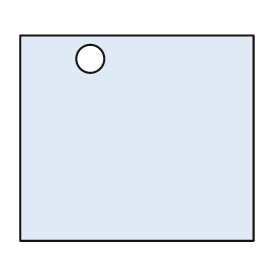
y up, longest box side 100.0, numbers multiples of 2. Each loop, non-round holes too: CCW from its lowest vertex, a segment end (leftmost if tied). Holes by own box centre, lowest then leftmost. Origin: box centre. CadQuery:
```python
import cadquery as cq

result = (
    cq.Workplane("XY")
    .moveTo(-50.0, -44.0)
    .lineTo(50.0, -44.0)
    .lineTo(50.0, 44.0)
    .lineTo(-50.0, 44.0)
    .close()
    .moveTo(-20.0, 34.0)
    .circle(6.0)
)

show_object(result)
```